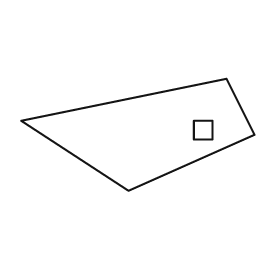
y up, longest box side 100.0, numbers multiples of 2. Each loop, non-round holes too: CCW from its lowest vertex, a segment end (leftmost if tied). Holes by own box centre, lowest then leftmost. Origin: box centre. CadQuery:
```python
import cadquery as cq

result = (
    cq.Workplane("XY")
    .moveTo(-4.0, -24.0)
    .lineTo(50.0, 0.0)
    .lineTo(38.0, 24.0)
    .lineTo(-50.0, 6.0)
    .close()
    .moveTo(24.0, -2.0)
    .lineTo(32.0, -2.0)
    .lineTo(32.0, 6.0)
    .lineTo(24.0, 6.0)
    .close()
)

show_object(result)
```